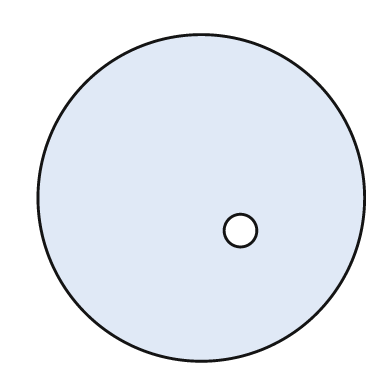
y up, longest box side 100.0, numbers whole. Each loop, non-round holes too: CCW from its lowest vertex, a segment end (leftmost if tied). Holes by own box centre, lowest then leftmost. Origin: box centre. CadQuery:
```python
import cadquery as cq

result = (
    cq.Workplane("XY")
    .moveTo(0.0, 0.0)
    .circle(50.0)
    .moveTo(12.0, -10.0)
    .circle(5.0)
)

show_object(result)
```